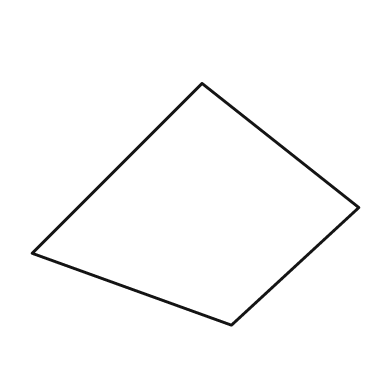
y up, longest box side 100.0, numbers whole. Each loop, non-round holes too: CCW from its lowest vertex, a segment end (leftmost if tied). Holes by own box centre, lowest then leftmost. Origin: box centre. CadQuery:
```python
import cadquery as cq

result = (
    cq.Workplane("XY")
    .moveTo(11.0, -37.0)
    .lineTo(50.0, -1.0)
    .lineTo(2.0, 37.0)
    .lineTo(-50.0, -15.0)
    .close()
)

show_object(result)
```